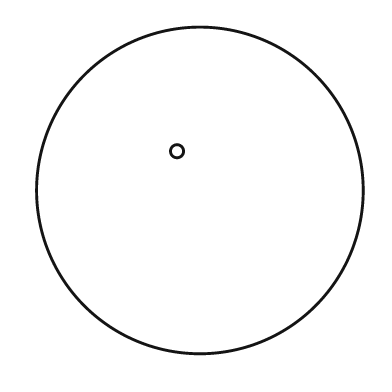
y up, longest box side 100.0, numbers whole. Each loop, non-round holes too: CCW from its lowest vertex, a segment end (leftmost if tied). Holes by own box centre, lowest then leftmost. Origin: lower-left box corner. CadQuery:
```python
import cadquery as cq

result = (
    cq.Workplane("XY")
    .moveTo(50.0, 50.0)
    .circle(50.0)
    .moveTo(43.0, 62.0)
    .circle(2.0)
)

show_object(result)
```